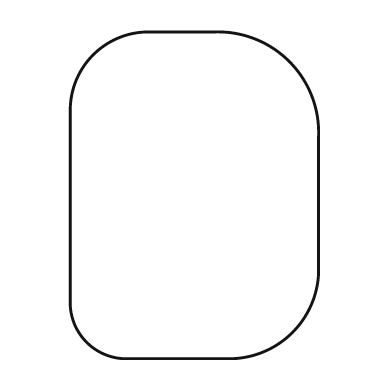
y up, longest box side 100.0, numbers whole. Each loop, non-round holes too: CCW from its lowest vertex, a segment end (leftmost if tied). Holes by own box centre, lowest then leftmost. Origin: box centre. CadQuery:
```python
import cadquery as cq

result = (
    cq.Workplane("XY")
    .moveTo(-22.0, -50.0)
    .lineTo(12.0, -50.0)
    .threePointArc((30.0, -42.0), (38.0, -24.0))
    .lineTo(38.0, 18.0)
    .threePointArc((29.0, 41.0), (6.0, 50.0))
    .lineTo(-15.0, 50.0)
    .threePointArc((-31.0, 43.0), (-38.0, 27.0))
    .lineTo(-38.0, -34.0)
    .threePointArc((-33.0, -45.0), (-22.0, -50.0))
    .close()
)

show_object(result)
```